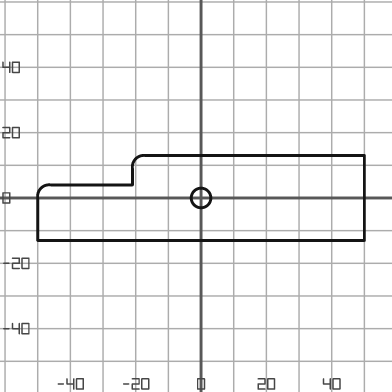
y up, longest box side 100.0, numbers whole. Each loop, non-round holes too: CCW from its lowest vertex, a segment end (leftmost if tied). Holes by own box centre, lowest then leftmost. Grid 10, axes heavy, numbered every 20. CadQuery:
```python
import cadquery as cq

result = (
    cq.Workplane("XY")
    .moveTo(-50.0, -13.0)
    .lineTo(50.0, -13.0)
    .lineTo(50.0, 13.0)
    .lineTo(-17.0, 13.0)
    .threePointArc((-20.0, 12.0), (-21.0, 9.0))
    .lineTo(-21.0, 4.0)
    .lineTo(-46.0, 4.0)
    .threePointArc((-49.0, 3.0), (-50.0, 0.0))
    .close()
    .moveTo(0.0, 0.0)
    .circle(3.0)
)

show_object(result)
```